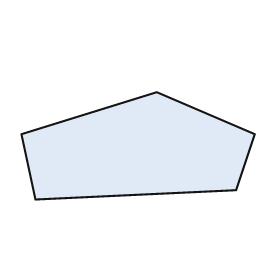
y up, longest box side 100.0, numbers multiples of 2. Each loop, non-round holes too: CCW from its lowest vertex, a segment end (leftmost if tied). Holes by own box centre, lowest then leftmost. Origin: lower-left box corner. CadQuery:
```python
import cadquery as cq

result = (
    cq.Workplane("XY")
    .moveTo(6.0, 0.0)
    .lineTo(92.0, 4.0)
    .lineTo(100.0, 28.0)
    .lineTo(58.0, 46.0)
    .lineTo(0.0, 28.0)
    .close()
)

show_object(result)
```